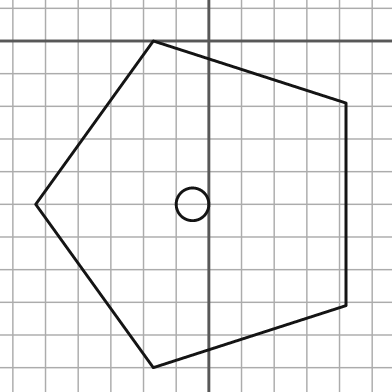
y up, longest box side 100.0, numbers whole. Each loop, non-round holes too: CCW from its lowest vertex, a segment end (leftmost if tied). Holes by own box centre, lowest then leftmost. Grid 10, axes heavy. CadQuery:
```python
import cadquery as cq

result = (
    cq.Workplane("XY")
    .moveTo(-17.0, -100.0)
    .lineTo(42.0, -81.0)
    .lineTo(42.0, -19.0)
    .lineTo(-17.0, 0.0)
    .lineTo(-53.0, -50.0)
    .close()
    .moveTo(-5.0, -50.0)
    .circle(5.0)
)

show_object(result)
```